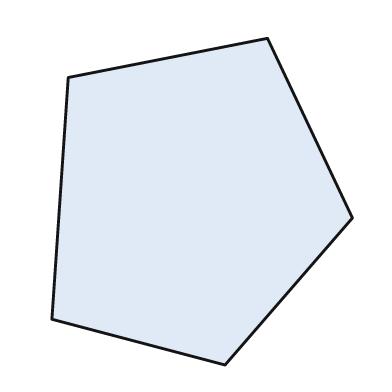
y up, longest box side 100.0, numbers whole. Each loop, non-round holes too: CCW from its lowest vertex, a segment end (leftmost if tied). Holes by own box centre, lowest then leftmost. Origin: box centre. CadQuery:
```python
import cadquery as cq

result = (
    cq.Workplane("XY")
    .moveTo(7.0, -50.0)
    .lineTo(46.0, -5.0)
    .lineTo(20.0, 50.0)
    .lineTo(-41.0, 38.0)
    .lineTo(-46.0, -36.0)
    .close()
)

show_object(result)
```